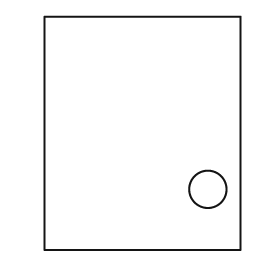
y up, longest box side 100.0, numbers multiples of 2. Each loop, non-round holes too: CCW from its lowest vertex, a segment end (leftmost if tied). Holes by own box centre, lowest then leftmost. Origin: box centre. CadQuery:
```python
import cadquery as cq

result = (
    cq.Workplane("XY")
    .moveTo(-42.0, -50.0)
    .lineTo(42.0, -50.0)
    .lineTo(42.0, 50.0)
    .lineTo(-42.0, 50.0)
    .close()
    .moveTo(28.0, -24.0)
    .circle(8.0)
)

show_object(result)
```